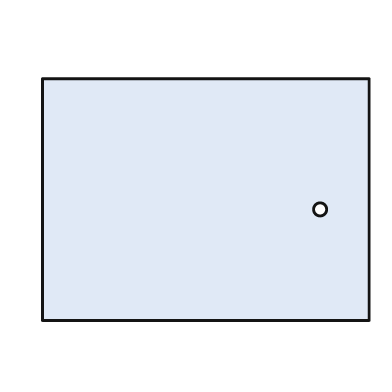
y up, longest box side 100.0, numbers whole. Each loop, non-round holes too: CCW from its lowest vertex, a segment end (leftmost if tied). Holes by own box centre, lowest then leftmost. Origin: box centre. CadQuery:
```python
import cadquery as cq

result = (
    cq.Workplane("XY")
    .moveTo(-50.0, -37.0)
    .lineTo(50.0, -37.0)
    .lineTo(50.0, 37.0)
    .lineTo(-50.0, 37.0)
    .close()
    .moveTo(35.0, -3.0)
    .circle(2.0)
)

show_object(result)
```